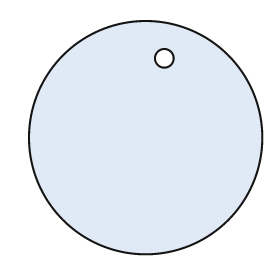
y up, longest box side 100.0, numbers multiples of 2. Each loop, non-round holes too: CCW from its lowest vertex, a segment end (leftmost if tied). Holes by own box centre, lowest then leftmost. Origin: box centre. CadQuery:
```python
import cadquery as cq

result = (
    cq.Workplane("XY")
    .moveTo(0.0, 0.0)
    .circle(50.0)
    .moveTo(8.0, 34.0)
    .circle(4.0)
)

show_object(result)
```